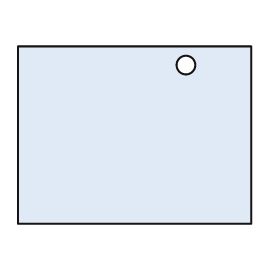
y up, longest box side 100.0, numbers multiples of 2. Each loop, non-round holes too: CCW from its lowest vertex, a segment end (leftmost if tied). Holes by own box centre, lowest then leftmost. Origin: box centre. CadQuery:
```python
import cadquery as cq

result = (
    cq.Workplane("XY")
    .moveTo(-50.0, -38.0)
    .lineTo(50.0, -38.0)
    .lineTo(50.0, 38.0)
    .lineTo(-50.0, 38.0)
    .close()
    .moveTo(22.0, 30.0)
    .circle(4.0)
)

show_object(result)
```